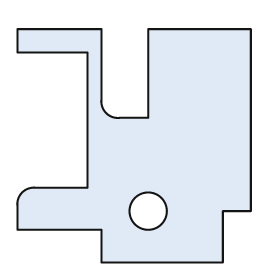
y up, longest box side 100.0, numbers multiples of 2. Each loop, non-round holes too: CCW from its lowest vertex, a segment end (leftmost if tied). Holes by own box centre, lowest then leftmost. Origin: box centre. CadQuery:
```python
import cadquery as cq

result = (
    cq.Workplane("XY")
    .moveTo(-14.0, -50.0)
    .lineTo(38.0, -50.0)
    .lineTo(38.0, -28.0)
    .lineTo(50.0, -28.0)
    .lineTo(50.0, 50.0)
    .lineTo(6.0, 50.0)
    .lineTo(6.0, 12.0)
    .lineTo(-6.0, 12.0)
    .threePointArc((-12.0, 14.0), (-14.0, 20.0))
    .lineTo(-14.0, 50.0)
    .lineTo(-50.0, 50.0)
    .lineTo(-50.0, 40.0)
    .lineTo(-20.0, 40.0)
    .lineTo(-20.0, -18.0)
    .lineTo(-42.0, -18.0)
    .threePointArc((-48.0, -20.0), (-50.0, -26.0))
    .lineTo(-50.0, -36.0)
    .lineTo(-14.0, -36.0)
    .close()
    .moveTo(6.0, -28.0)
    .circle(8.0)
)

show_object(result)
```